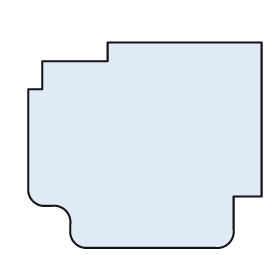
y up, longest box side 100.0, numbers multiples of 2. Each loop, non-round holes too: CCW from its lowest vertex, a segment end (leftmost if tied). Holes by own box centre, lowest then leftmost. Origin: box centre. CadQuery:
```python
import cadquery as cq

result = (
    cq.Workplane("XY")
    .moveTo(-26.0, -44.0)
    .lineTo(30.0, -44.0)
    .threePointArc((36.0, -42.0), (38.0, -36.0))
    .lineTo(38.0, -22.0)
    .lineTo(50.0, -22.0)
    .lineTo(50.0, 44.0)
    .lineTo(-16.0, 44.0)
    .lineTo(-16.0, 36.0)
    .lineTo(-44.0, 36.0)
    .lineTo(-44.0, 24.0)
    .lineTo(-50.0, 24.0)
    .lineTo(-50.0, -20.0)
    .threePointArc((-48.0, -24.0), (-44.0, -26.0))
    .lineTo(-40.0, -26.0)
    .threePointArc((-34.0, -28.0), (-32.0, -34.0))
    .lineTo(-32.0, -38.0)
    .threePointArc((-30.0, -42.0), (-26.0, -44.0))
    .close()
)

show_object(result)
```